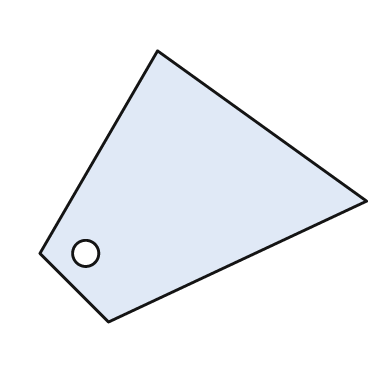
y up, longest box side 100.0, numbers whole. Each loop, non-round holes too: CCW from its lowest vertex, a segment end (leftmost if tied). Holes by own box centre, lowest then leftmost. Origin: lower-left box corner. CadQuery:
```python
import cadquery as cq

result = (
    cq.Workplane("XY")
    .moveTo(21.0, 0.0)
    .lineTo(100.0, 37.0)
    .lineTo(36.0, 83.0)
    .lineTo(0.0, 21.0)
    .close()
    .moveTo(14.0, 21.0)
    .circle(4.0)
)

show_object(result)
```